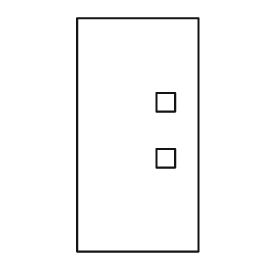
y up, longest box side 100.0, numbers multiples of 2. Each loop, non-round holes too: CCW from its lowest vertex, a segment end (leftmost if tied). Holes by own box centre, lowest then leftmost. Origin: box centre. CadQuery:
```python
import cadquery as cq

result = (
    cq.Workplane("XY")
    .moveTo(-26.0, -50.0)
    .lineTo(26.0, -50.0)
    .lineTo(26.0, 50.0)
    .lineTo(-26.0, 50.0)
    .close()
    .moveTo(8.0, -14.0)
    .lineTo(16.0, -14.0)
    .lineTo(16.0, -6.0)
    .lineTo(8.0, -6.0)
    .close()
    .moveTo(8.0, 10.0)
    .lineTo(16.0, 10.0)
    .lineTo(16.0, 18.0)
    .lineTo(8.0, 18.0)
    .close()
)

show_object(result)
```